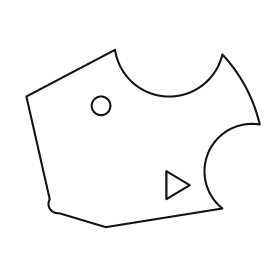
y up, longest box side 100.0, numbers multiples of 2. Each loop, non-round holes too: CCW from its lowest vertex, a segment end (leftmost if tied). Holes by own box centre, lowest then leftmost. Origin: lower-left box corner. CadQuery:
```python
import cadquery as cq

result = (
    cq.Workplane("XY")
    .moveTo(34.0, 0.0)
    .lineTo(84.0, 8.0)
    .threePointArc((78.0, 32.0), (100.0, 44.0))
    .threePointArc((94.0, 60.0), (84.0, 74.0))
    .threePointArc((60.0, 56.0), (38.0, 76.0))
    .lineTo(0.0, 56.0)
    .lineTo(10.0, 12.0)
    .threePointArc((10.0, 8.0), (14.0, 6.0))
    .close()
    .moveTo(60.0, 12.0)
    .lineTo(70.0, 18.0)
    .lineTo(60.0, 24.0)
    .close()
    .moveTo(32.0, 52.0)
    .circle(4.0)
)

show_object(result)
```